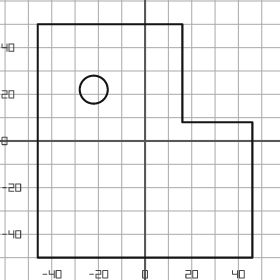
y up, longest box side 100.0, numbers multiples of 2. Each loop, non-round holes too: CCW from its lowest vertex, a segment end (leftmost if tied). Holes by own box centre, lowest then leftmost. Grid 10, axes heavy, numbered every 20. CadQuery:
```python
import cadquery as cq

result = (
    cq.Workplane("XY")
    .moveTo(-46.0, -50.0)
    .lineTo(46.0, -50.0)
    .lineTo(46.0, 8.0)
    .lineTo(16.0, 8.0)
    .lineTo(16.0, 50.0)
    .lineTo(-46.0, 50.0)
    .close()
    .moveTo(-22.0, 22.0)
    .circle(6.0)
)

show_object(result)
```